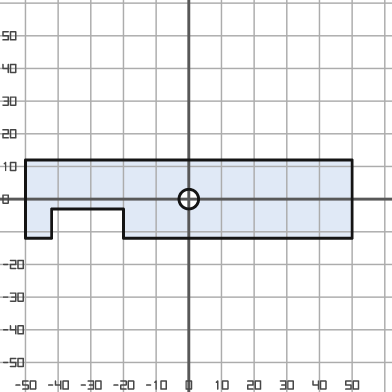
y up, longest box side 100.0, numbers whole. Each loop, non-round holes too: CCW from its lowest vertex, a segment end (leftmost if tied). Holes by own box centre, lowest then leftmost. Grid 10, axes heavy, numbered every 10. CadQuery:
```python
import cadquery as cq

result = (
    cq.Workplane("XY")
    .moveTo(-50.0, -12.0)
    .lineTo(-42.0, -12.0)
    .lineTo(-42.0, -3.0)
    .lineTo(-20.0, -3.0)
    .lineTo(-20.0, -12.0)
    .lineTo(50.0, -12.0)
    .lineTo(50.0, 12.0)
    .lineTo(-50.0, 12.0)
    .close()
    .moveTo(0.0, 0.0)
    .circle(3.0)
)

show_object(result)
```